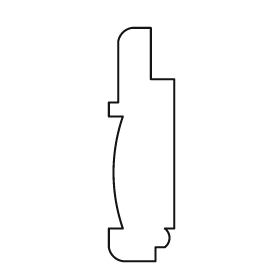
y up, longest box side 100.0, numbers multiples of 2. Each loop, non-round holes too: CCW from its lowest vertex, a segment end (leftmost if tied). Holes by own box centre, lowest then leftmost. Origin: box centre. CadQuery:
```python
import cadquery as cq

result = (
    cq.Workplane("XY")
    .moveTo(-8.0, -50.0)
    .lineTo(6.0, -50.0)
    .lineTo(6.0, -44.0)
    .lineTo(10.0, -44.0)
    .threePointArc((12.0, -40.0), (10.0, -36.0))
    .lineTo(14.0, -36.0)
    .lineTo(14.0, 28.0)
    .lineTo(4.0, 28.0)
    .lineTo(4.0, 50.0)
    .lineTo(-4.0, 50.0)
    .threePointArc((-8.0, 48.0), (-10.0, 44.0))
    .lineTo(-10.0, 18.0)
    .lineTo(-14.0, 18.0)
    .lineTo(-14.0, 12.0)
    .lineTo(-8.0, 12.0)
    .threePointArc((-12.0, -12.0), (-8.0, -36.0))
    .lineTo(-14.0, -36.0)
    .lineTo(-14.0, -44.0)
    .threePointArc((-12.0, -48.0), (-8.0, -50.0))
    .close()
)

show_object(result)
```